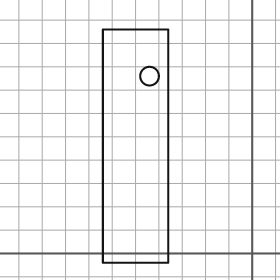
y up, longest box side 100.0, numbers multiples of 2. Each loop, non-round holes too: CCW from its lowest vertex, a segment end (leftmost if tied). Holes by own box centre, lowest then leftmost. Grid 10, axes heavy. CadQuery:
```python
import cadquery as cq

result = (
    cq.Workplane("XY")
    .moveTo(-64.0, -4.0)
    .lineTo(-36.0, -4.0)
    .lineTo(-36.0, 96.0)
    .lineTo(-64.0, 96.0)
    .close()
    .moveTo(-44.0, 76.0)
    .circle(4.0)
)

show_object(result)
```